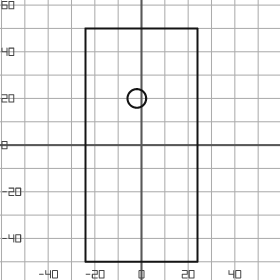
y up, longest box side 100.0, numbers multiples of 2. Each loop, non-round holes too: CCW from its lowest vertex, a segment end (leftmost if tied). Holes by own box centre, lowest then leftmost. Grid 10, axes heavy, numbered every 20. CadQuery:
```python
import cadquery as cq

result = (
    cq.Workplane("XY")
    .moveTo(-24.0, -50.0)
    .lineTo(24.0, -50.0)
    .lineTo(24.0, 50.0)
    .lineTo(-24.0, 50.0)
    .close()
    .moveTo(-2.0, 20.0)
    .circle(4.0)
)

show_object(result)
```